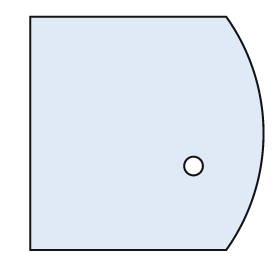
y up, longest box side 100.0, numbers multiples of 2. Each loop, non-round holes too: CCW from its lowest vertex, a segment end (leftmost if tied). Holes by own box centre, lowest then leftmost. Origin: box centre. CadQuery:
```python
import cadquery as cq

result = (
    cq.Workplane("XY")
    .moveTo(-50.0, -50.0)
    .lineTo(34.0, -50.0)
    .threePointArc((50.0, 0.0), (34.0, 50.0))
    .lineTo(-50.0, 50.0)
    .close()
    .moveTo(20.0, -14.0)
    .circle(4.0)
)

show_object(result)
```